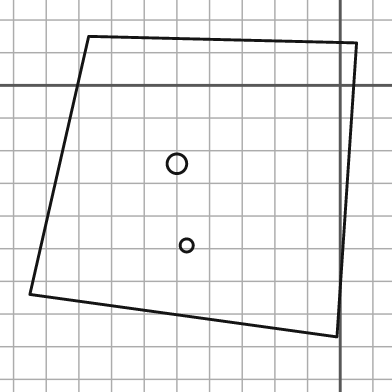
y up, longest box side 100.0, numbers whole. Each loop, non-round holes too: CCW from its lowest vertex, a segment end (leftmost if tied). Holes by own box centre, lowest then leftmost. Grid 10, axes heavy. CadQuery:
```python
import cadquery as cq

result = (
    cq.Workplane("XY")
    .moveTo(-1.0, -77.0)
    .lineTo(5.0, 13.0)
    .lineTo(-77.0, 15.0)
    .lineTo(-95.0, -64.0)
    .close()
    .moveTo(-47.0, -49.0)
    .circle(2.0)
    .moveTo(-50.0, -24.0)
    .circle(3.0)
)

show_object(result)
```